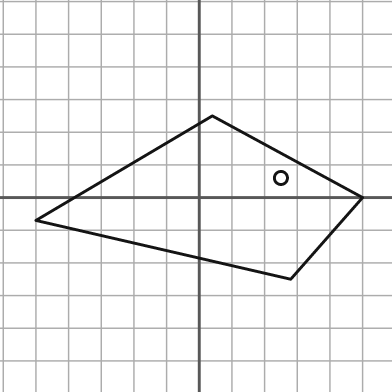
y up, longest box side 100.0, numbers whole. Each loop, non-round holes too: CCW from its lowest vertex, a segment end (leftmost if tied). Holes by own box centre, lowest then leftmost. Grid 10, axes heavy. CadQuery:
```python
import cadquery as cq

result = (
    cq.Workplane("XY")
    .moveTo(28.0, -25.0)
    .lineTo(50.0, 0.0)
    .lineTo(4.0, 25.0)
    .lineTo(-50.0, -7.0)
    .close()
    .moveTo(25.0, 6.0)
    .circle(2.0)
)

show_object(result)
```